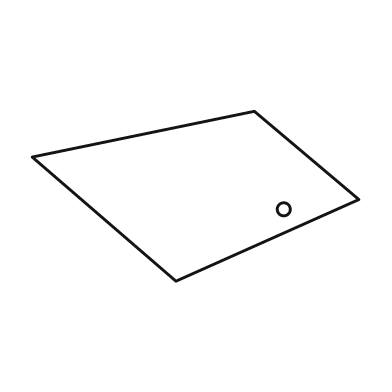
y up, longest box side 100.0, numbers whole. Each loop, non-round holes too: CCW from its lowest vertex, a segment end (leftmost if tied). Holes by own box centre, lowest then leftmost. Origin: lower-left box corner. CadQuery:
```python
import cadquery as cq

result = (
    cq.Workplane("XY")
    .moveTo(44.0, 0.0)
    .lineTo(100.0, 25.0)
    .lineTo(68.0, 52.0)
    .lineTo(0.0, 38.0)
    .close()
    .moveTo(77.0, 22.0)
    .circle(2.0)
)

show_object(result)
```